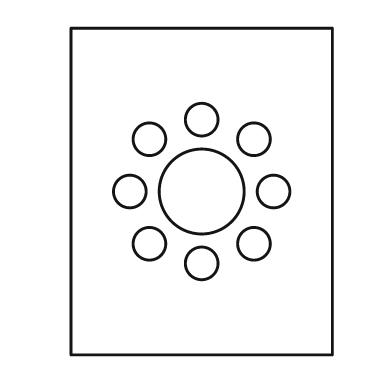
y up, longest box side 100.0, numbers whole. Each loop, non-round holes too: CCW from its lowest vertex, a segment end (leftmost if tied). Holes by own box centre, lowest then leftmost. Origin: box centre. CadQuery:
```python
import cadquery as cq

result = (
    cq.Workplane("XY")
    .moveTo(-40.0, -50.0)
    .lineTo(40.0, -50.0)
    .lineTo(40.0, 50.0)
    .lineTo(-40.0, 50.0)
    .close()
    .moveTo(0.0, -22.0)
    .circle(5.0)
    .moveTo(-16.0, -16.0)
    .circle(5.0)
    .moveTo(16.0, -16.0)
    .circle(5.0)
    .moveTo(-22.0, 0.0)
    .circle(5.0)
    .moveTo(0.0, 0.0)
    .circle(13.0)
    .moveTo(22.0, 0.0)
    .circle(5.0)
    .moveTo(-16.0, 16.0)
    .circle(5.0)
    .moveTo(16.0, 16.0)
    .circle(5.0)
    .moveTo(0.0, 22.0)
    .circle(5.0)
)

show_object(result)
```